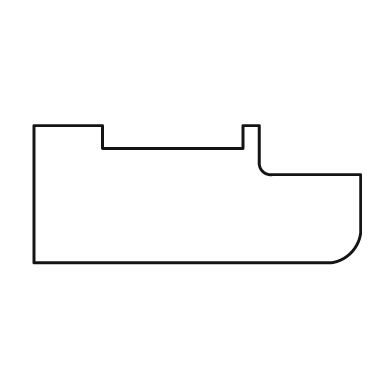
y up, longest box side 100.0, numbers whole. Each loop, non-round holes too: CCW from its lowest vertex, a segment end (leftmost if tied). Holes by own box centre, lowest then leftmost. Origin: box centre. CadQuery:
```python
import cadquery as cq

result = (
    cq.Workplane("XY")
    .moveTo(-50.0, -21.0)
    .lineTo(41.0, -21.0)
    .threePointArc((47.0, -18.0), (50.0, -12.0))
    .lineTo(50.0, 6.0)
    .lineTo(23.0, 6.0)
    .threePointArc((20.0, 7.0), (19.0, 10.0))
    .lineTo(19.0, 21.0)
    .lineTo(14.0, 21.0)
    .lineTo(14.0, 14.0)
    .lineTo(-29.0, 14.0)
    .lineTo(-29.0, 21.0)
    .lineTo(-50.0, 21.0)
    .close()
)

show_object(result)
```